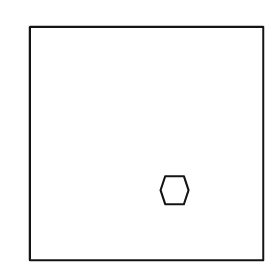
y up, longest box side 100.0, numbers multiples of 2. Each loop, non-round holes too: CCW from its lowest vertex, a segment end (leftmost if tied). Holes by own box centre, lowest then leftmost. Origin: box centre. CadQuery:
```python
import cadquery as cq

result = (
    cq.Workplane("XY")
    .moveTo(-50.0, -50.0)
    .lineTo(50.0, -50.0)
    .lineTo(50.0, 50.0)
    .lineTo(-50.0, 50.0)
    .close()
    .moveTo(8.0, -26.0)
    .lineTo(16.0, -26.0)
    .lineTo(18.0, -20.0)
    .lineTo(16.0, -14.0)
    .lineTo(8.0, -14.0)
    .lineTo(6.0, -20.0)
    .close()
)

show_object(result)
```